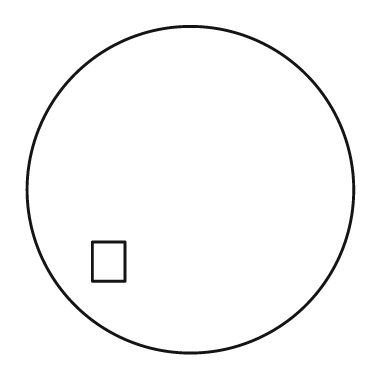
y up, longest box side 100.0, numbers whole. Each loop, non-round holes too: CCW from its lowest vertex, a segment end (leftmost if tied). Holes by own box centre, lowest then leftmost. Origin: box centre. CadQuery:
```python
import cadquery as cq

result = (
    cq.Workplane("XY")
    .moveTo(0.0, 0.0)
    .circle(50.0)
    .moveTo(-30.0, -28.0)
    .lineTo(-20.0, -28.0)
    .lineTo(-20.0, -16.0)
    .lineTo(-30.0, -16.0)
    .close()
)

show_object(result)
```